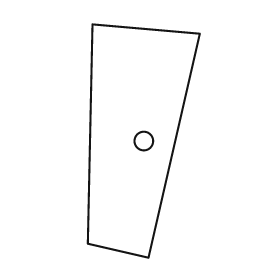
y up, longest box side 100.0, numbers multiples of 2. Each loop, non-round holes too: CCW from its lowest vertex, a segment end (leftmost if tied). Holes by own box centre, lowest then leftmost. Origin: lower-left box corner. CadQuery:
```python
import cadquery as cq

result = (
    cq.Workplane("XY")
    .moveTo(26.0, 0.0)
    .lineTo(48.0, 96.0)
    .lineTo(2.0, 100.0)
    .lineTo(0.0, 6.0)
    .close()
    .moveTo(24.0, 50.0)
    .circle(4.0)
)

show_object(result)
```